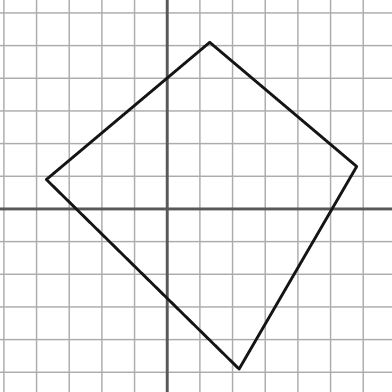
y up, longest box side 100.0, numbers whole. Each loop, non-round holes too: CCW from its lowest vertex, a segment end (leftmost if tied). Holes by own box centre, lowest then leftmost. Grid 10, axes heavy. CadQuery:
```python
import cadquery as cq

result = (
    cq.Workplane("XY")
    .moveTo(22.0, -49.0)
    .lineTo(58.0, 13.0)
    .lineTo(13.0, 51.0)
    .lineTo(-37.0, 9.0)
    .close()
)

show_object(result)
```